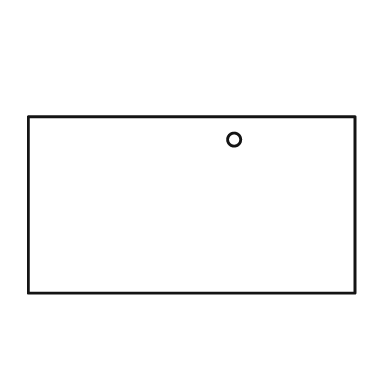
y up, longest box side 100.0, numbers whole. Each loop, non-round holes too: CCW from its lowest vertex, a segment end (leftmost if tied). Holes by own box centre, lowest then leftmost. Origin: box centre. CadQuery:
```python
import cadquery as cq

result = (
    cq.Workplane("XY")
    .moveTo(-50.0, -27.0)
    .lineTo(50.0, -27.0)
    .lineTo(50.0, 27.0)
    .lineTo(-50.0, 27.0)
    .close()
    .moveTo(13.0, 20.0)
    .circle(2.0)
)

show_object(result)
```